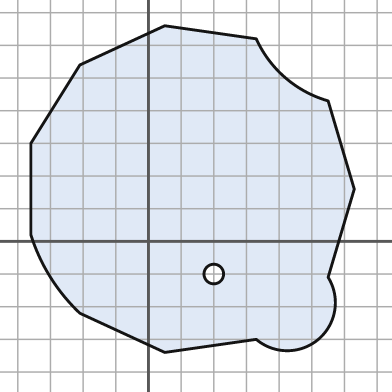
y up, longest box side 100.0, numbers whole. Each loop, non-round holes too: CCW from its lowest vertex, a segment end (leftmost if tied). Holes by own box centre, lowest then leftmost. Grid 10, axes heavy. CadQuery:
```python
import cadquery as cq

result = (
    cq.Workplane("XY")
    .moveTo(5.0, -34.0)
    .lineTo(33.0, -30.0)
    .threePointArc((52.0, -30.0), (55.0, -11.0))
    .lineTo(63.0, 16.0)
    .lineTo(55.0, 43.0)
    .threePointArc((42.0, 50.0), (33.0, 62.0))
    .lineTo(5.0, 66.0)
    .lineTo(-21.0, 54.0)
    .lineTo(-36.0, 30.0)
    .lineTo(-36.0, 2.0)
    .threePointArc((-30.0, -11.0), (-21.0, -22.0))
    .close()
    .moveTo(20.0, -10.0)
    .circle(3.0)
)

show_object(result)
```